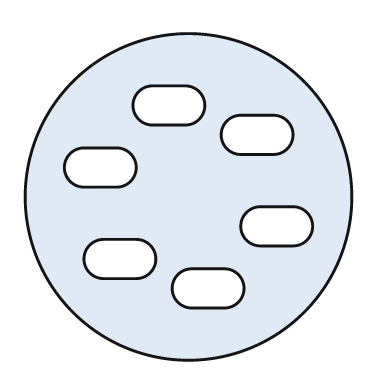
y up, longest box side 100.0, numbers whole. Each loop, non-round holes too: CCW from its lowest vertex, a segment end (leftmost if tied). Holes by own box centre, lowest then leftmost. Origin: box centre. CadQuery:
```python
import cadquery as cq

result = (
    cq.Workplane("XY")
    .moveTo(0.0, 0.0)
    .circle(50.0)
    .moveTo(1.0, -34.0)
    .lineTo(11.0, -34.0)
    .threePointArc((17.0, -28.0), (11.0, -22.0))
    .lineTo(1.0, -22.0)
    .threePointArc((-5.0, -28.0), (1.0, -34.0))
    .close()
    .moveTo(-26.0, -25.0)
    .lineTo(-16.0, -25.0)
    .threePointArc((-10.0, -19.0), (-16.0, -13.0))
    .lineTo(-26.0, -13.0)
    .threePointArc((-32.0, -19.0), (-26.0, -25.0))
    .close()
    .moveTo(22.0, -15.0)
    .lineTo(32.0, -15.0)
    .threePointArc((38.0, -9.0), (32.0, -3.0))
    .lineTo(22.0, -3.0)
    .threePointArc((16.0, -9.0), (22.0, -15.0))
    .close()
    .moveTo(-32.0, 3.0)
    .lineTo(-22.0, 3.0)
    .threePointArc((-16.0, 9.0), (-22.0, 15.0))
    .lineTo(-32.0, 15.0)
    .threePointArc((-38.0, 9.0), (-32.0, 3.0))
    .close()
    .moveTo(16.0, 13.0)
    .lineTo(26.0, 13.0)
    .threePointArc((32.0, 19.0), (26.0, 25.0))
    .lineTo(16.0, 25.0)
    .threePointArc((10.0, 19.0), (16.0, 13.0))
    .close()
    .moveTo(-11.0, 22.0)
    .lineTo(-1.0, 22.0)
    .threePointArc((5.0, 28.0), (-1.0, 34.0))
    .lineTo(-11.0, 34.0)
    .threePointArc((-17.0, 28.0), (-11.0, 22.0))
    .close()
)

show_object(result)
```